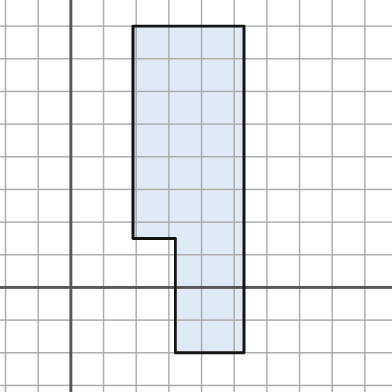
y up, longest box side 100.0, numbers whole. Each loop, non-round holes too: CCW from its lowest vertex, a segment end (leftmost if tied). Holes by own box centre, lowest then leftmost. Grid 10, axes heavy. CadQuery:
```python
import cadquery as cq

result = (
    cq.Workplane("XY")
    .moveTo(32.0, -20.0)
    .lineTo(53.0, -20.0)
    .lineTo(53.0, 80.0)
    .lineTo(19.0, 80.0)
    .lineTo(19.0, 15.0)
    .lineTo(32.0, 15.0)
    .close()
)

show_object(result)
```